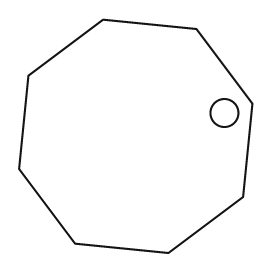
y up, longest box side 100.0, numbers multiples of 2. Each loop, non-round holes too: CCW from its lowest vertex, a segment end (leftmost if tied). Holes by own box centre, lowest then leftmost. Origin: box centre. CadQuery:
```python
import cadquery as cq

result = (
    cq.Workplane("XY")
    .moveTo(14.0, -50.0)
    .lineTo(46.0, -26.0)
    .lineTo(50.0, 14.0)
    .lineTo(26.0, 46.0)
    .lineTo(-14.0, 50.0)
    .lineTo(-46.0, 26.0)
    .lineTo(-50.0, -14.0)
    .lineTo(-26.0, -46.0)
    .close()
    .moveTo(38.0, 10.0)
    .circle(6.0)
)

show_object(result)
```